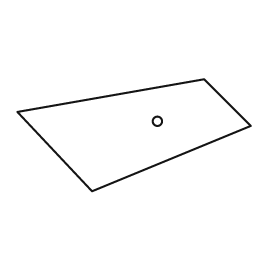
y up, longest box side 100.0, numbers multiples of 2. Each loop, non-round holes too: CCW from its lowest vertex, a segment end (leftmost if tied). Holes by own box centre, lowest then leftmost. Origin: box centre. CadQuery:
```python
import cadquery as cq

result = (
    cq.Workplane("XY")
    .moveTo(-18.0, -24.0)
    .lineTo(50.0, 4.0)
    .lineTo(30.0, 24.0)
    .lineTo(-50.0, 10.0)
    .close()
    .moveTo(10.0, 6.0)
    .circle(2.0)
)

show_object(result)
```